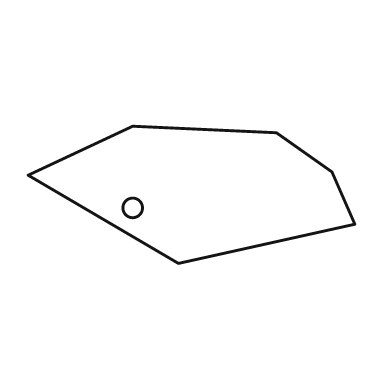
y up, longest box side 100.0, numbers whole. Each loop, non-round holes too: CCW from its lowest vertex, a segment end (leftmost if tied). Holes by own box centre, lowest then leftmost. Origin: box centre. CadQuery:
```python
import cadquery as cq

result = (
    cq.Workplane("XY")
    .moveTo(-4.0, -21.0)
    .lineTo(50.0, -9.0)
    .lineTo(43.0, 7.0)
    .lineTo(26.0, 19.0)
    .lineTo(-18.0, 21.0)
    .lineTo(-50.0, 6.0)
    .close()
    .moveTo(-18.0, -4.0)
    .circle(3.0)
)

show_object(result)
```